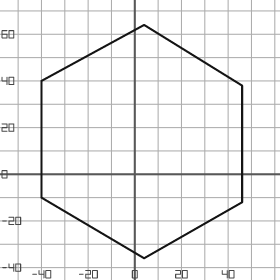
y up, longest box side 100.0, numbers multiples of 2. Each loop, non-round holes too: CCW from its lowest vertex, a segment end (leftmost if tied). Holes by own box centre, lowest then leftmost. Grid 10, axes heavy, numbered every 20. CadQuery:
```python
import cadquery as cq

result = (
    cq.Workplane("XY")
    .moveTo(4.0, -36.0)
    .lineTo(46.0, -12.0)
    .lineTo(46.0, 38.0)
    .lineTo(4.0, 64.0)
    .lineTo(-40.0, 40.0)
    .lineTo(-40.0, -10.0)
    .close()
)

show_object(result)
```